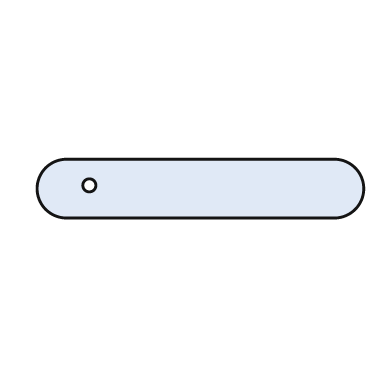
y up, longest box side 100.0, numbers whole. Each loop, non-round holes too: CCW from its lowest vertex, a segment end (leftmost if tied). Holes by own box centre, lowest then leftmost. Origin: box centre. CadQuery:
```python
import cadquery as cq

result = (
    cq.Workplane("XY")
    .moveTo(-41.0, -9.0)
    .lineTo(41.0, -9.0)
    .threePointArc((50.0, 0.0), (41.0, 9.0))
    .lineTo(-41.0, 9.0)
    .threePointArc((-50.0, 0.0), (-41.0, -9.0))
    .close()
    .moveTo(-34.0, 1.0)
    .circle(2.0)
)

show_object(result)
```